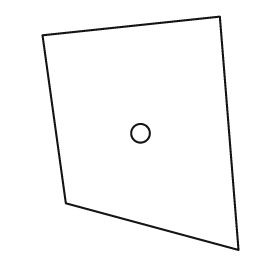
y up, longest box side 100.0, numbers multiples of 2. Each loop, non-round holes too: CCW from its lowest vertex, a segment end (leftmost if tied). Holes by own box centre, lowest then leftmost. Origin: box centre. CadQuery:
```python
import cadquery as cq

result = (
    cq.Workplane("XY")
    .moveTo(42.0, -50.0)
    .lineTo(34.0, 50.0)
    .lineTo(-42.0, 42.0)
    .lineTo(-32.0, -30.0)
    .close()
    .moveTo(0.0, 0.0)
    .circle(4.0)
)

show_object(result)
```